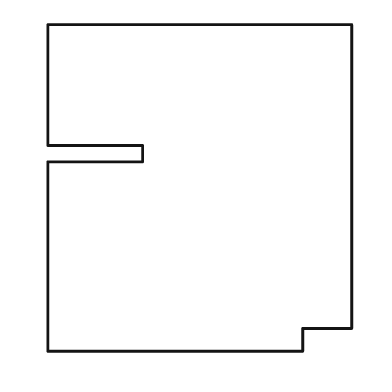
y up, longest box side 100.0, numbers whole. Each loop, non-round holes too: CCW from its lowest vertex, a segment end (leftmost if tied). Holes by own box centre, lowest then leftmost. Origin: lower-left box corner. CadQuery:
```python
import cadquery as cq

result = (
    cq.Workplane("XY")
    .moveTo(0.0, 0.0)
    .lineTo(78.0, 0.0)
    .lineTo(78.0, 7.0)
    .lineTo(93.0, 7.0)
    .lineTo(93.0, 100.0)
    .lineTo(0.0, 100.0)
    .lineTo(0.0, 63.0)
    .lineTo(29.0, 63.0)
    .lineTo(29.0, 58.0)
    .lineTo(0.0, 58.0)
    .close()
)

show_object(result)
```